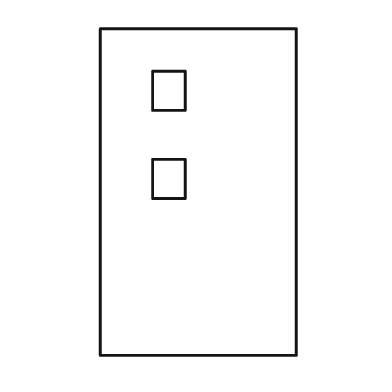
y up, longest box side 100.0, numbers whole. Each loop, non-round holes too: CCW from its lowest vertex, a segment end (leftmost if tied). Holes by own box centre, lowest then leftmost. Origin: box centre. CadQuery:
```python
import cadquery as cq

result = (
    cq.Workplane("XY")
    .moveTo(-30.0, -50.0)
    .lineTo(30.0, -50.0)
    .lineTo(30.0, 50.0)
    .lineTo(-30.0, 50.0)
    .close()
    .moveTo(-14.0, -2.0)
    .lineTo(-4.0, -2.0)
    .lineTo(-4.0, 10.0)
    .lineTo(-14.0, 10.0)
    .close()
    .moveTo(-14.0, 25.0)
    .lineTo(-4.0, 25.0)
    .lineTo(-4.0, 37.0)
    .lineTo(-14.0, 37.0)
    .close()
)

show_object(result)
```